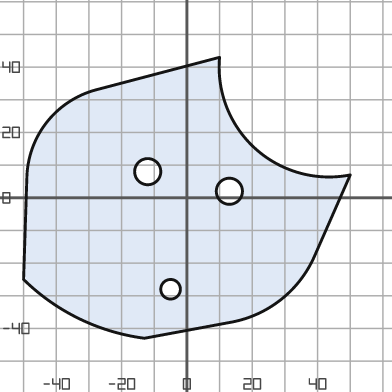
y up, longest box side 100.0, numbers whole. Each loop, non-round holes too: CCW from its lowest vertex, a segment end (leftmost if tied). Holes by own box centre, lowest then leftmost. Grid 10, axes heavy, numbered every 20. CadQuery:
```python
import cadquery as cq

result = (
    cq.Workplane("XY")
    .moveTo(-13.0, -43.0)
    .lineTo(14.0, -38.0)
    .threePointArc((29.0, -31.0), (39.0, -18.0))
    .lineTo(50.0, 7.0)
    .threePointArc((21.0, 15.0), (10.0, 43.0))
    .lineTo(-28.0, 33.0)
    .threePointArc((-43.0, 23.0), (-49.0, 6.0))
    .lineTo(-50.0, -25.0)
    .threePointArc((-33.0, -37.0), (-13.0, -43.0))
    .close()
    .moveTo(-5.0, -28.0)
    .circle(3.0)
    .moveTo(13.0, 2.0)
    .circle(4.0)
    .moveTo(-12.0, 8.0)
    .circle(4.0)
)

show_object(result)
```